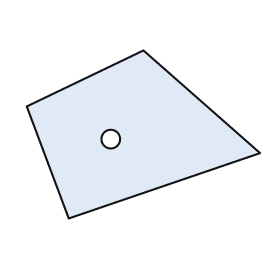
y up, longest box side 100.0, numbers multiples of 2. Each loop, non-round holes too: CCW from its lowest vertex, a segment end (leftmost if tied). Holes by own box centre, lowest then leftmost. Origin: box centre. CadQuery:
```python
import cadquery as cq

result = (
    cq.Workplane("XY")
    .moveTo(-32.0, -36.0)
    .lineTo(50.0, -8.0)
    .lineTo(0.0, 36.0)
    .lineTo(-50.0, 12.0)
    .close()
    .moveTo(-14.0, -2.0)
    .circle(4.0)
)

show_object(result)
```